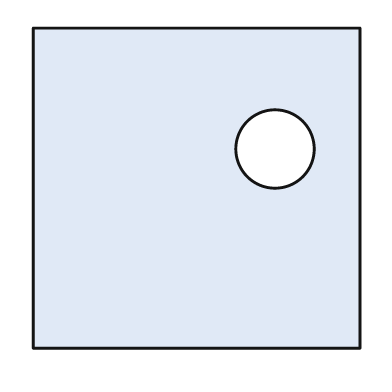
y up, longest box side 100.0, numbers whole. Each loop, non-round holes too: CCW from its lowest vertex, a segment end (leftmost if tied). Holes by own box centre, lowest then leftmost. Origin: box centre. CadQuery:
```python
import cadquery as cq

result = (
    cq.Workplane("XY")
    .moveTo(-50.0, -49.0)
    .lineTo(50.0, -49.0)
    .lineTo(50.0, 49.0)
    .lineTo(-50.0, 49.0)
    .close()
    .moveTo(24.0, 12.0)
    .circle(12.0)
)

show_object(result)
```